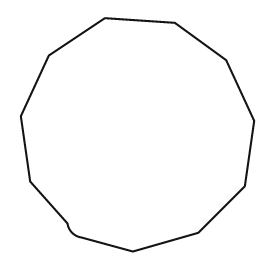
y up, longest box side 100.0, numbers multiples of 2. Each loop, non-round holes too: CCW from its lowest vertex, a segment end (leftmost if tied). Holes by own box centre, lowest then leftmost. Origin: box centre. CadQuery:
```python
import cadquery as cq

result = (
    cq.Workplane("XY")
    .moveTo(-2.0, -50.0)
    .lineTo(26.0, -42.0)
    .lineTo(46.0, -22.0)
    .lineTo(50.0, 6.0)
    .lineTo(38.0, 32.0)
    .lineTo(16.0, 48.0)
    .lineTo(-14.0, 50.0)
    .lineTo(-38.0, 34.0)
    .lineTo(-50.0, 8.0)
    .lineTo(-46.0, -20.0)
    .lineTo(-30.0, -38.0)
    .threePointArc((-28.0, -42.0), (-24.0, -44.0))
    .close()
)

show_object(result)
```